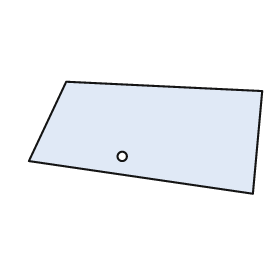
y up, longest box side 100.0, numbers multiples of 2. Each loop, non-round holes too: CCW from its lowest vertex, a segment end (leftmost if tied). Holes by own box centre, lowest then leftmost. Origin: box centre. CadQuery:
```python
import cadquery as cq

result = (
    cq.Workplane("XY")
    .moveTo(46.0, -24.0)
    .lineTo(50.0, 20.0)
    .lineTo(-34.0, 24.0)
    .lineTo(-50.0, -10.0)
    .close()
    .moveTo(-10.0, -8.0)
    .circle(2.0)
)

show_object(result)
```